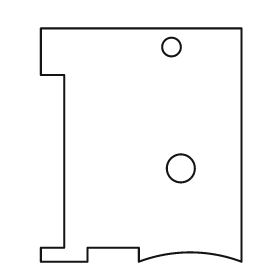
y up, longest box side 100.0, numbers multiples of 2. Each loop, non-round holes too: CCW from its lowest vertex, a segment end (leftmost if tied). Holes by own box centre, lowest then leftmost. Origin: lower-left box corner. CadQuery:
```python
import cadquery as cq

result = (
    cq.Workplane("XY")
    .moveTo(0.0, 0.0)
    .lineTo(20.0, 0.0)
    .lineTo(20.0, 6.0)
    .lineTo(42.0, 6.0)
    .lineTo(42.0, 0.0)
    .threePointArc((64.0, 4.0), (86.0, 0.0))
    .lineTo(86.0, 100.0)
    .lineTo(0.0, 100.0)
    .lineTo(0.0, 80.0)
    .lineTo(10.0, 80.0)
    .lineTo(10.0, 6.0)
    .lineTo(0.0, 6.0)
    .close()
    .moveTo(60.0, 40.0)
    .circle(6.0)
    .moveTo(56.0, 92.0)
    .circle(4.0)
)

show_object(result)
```